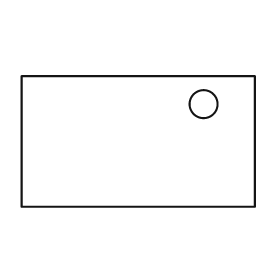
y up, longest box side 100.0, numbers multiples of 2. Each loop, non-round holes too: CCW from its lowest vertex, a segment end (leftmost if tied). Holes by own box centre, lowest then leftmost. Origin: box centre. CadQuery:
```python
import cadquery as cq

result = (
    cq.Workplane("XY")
    .moveTo(-50.0, -28.0)
    .lineTo(50.0, -28.0)
    .lineTo(50.0, 28.0)
    .lineTo(-50.0, 28.0)
    .close()
    .moveTo(28.0, 16.0)
    .circle(6.0)
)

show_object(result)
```